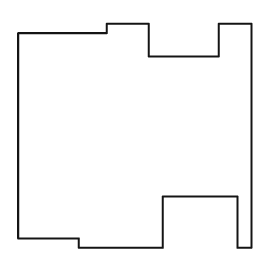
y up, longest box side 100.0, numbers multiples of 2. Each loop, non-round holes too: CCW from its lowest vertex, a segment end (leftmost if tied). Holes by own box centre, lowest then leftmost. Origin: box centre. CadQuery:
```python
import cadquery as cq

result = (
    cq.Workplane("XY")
    .moveTo(-24.0, -48.0)
    .lineTo(12.0, -48.0)
    .lineTo(12.0, -26.0)
    .lineTo(44.0, -26.0)
    .lineTo(44.0, -48.0)
    .lineTo(50.0, -48.0)
    .lineTo(50.0, 48.0)
    .lineTo(36.0, 48.0)
    .lineTo(36.0, 34.0)
    .lineTo(6.0, 34.0)
    .lineTo(6.0, 48.0)
    .lineTo(-12.0, 48.0)
    .lineTo(-12.0, 44.0)
    .lineTo(-50.0, 44.0)
    .lineTo(-50.0, -44.0)
    .lineTo(-24.0, -44.0)
    .close()
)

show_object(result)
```